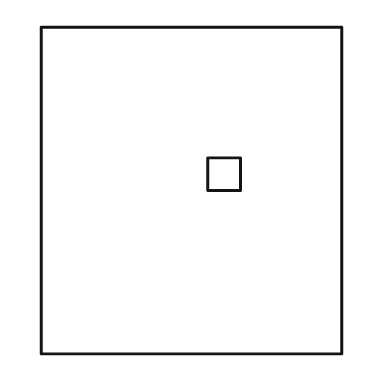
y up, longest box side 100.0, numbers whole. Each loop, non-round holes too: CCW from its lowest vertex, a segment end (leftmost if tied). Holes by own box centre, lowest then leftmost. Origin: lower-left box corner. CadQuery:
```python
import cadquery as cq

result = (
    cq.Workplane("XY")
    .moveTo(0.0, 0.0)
    .lineTo(92.0, 0.0)
    .lineTo(92.0, 100.0)
    .lineTo(0.0, 100.0)
    .close()
    .moveTo(51.0, 50.0)
    .lineTo(61.0, 50.0)
    .lineTo(61.0, 60.0)
    .lineTo(51.0, 60.0)
    .close()
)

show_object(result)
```